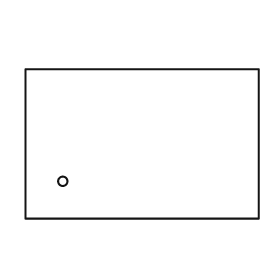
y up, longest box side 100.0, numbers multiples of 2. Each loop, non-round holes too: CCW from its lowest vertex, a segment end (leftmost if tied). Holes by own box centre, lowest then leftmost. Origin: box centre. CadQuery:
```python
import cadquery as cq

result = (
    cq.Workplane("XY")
    .moveTo(-50.0, -32.0)
    .lineTo(50.0, -32.0)
    .lineTo(50.0, 32.0)
    .lineTo(-50.0, 32.0)
    .close()
    .moveTo(-34.0, -16.0)
    .circle(2.0)
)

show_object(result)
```